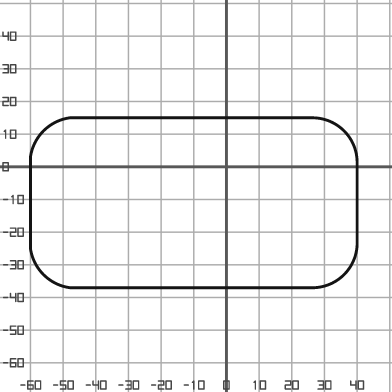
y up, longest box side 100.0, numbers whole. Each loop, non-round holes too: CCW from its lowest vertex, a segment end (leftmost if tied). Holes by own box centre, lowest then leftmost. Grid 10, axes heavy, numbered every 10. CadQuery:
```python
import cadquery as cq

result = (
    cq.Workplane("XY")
    .moveTo(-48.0, -37.0)
    .lineTo(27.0, -37.0)
    .threePointArc((36.0, -33.0), (40.0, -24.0))
    .lineTo(40.0, 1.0)
    .threePointArc((36.0, 11.0), (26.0, 15.0))
    .lineTo(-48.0, 15.0)
    .threePointArc((-56.0, 11.0), (-60.0, 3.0))
    .lineTo(-60.0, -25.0)
    .threePointArc((-56.0, -33.0), (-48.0, -37.0))
    .close()
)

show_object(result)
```